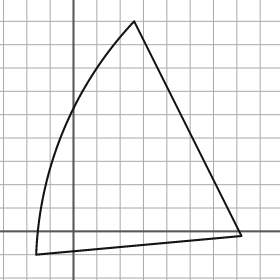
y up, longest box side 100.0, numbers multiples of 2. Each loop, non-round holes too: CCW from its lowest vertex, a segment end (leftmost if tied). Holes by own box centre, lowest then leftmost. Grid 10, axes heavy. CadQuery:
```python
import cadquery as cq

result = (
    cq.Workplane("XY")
    .moveTo(-16.0, -10.0)
    .lineTo(72.0, -2.0)
    .lineTo(26.0, 90.0)
    .threePointArc((-4.0, 44.0), (-16.0, -10.0))
    .close()
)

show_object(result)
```